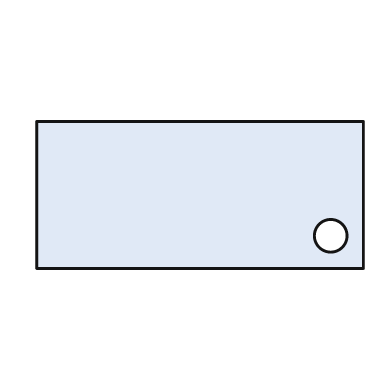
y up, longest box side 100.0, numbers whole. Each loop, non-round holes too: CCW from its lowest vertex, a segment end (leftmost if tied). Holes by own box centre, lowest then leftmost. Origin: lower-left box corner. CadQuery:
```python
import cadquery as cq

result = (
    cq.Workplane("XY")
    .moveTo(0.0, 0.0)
    .lineTo(100.0, 0.0)
    .lineTo(100.0, 45.0)
    .lineTo(0.0, 45.0)
    .close()
    .moveTo(90.0, 10.0)
    .circle(5.0)
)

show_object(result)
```